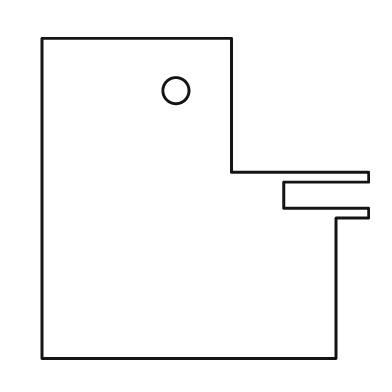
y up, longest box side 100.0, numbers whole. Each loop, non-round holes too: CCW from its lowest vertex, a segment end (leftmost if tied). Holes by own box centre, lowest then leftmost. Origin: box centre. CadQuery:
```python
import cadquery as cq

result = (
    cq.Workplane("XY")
    .moveTo(-50.0, -49.0)
    .lineTo(40.0, -49.0)
    .lineTo(40.0, -6.0)
    .lineTo(50.0, -6.0)
    .lineTo(50.0, -3.0)
    .lineTo(24.0, -3.0)
    .lineTo(24.0, 5.0)
    .lineTo(50.0, 5.0)
    .lineTo(50.0, 8.0)
    .lineTo(8.0, 8.0)
    .lineTo(8.0, 49.0)
    .lineTo(-50.0, 49.0)
    .close()
    .moveTo(-9.0, 33.0)
    .circle(4.0)
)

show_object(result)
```